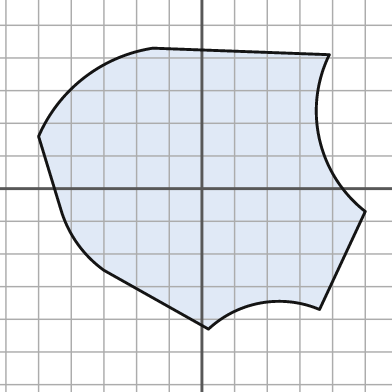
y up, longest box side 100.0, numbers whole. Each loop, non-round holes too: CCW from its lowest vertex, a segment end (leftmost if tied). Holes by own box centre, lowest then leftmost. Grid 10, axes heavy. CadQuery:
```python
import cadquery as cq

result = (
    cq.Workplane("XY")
    .moveTo(2.0, -43.0)
    .threePointArc((18.0, -35.0), (36.0, -37.0))
    .lineTo(50.0, -7.0)
    .threePointArc((36.0, 15.0), (39.0, 41.0))
    .lineTo(-15.0, 43.0)
    .threePointArc((-36.0, 34.0), (-50.0, 16.0))
    .lineTo(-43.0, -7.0)
    .threePointArc((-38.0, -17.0), (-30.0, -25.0))
    .close()
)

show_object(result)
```